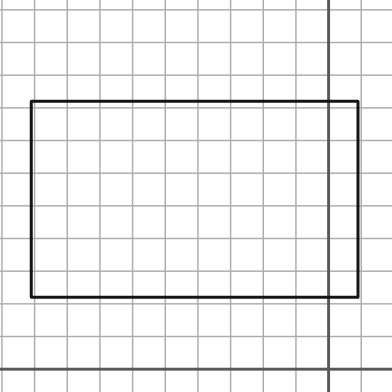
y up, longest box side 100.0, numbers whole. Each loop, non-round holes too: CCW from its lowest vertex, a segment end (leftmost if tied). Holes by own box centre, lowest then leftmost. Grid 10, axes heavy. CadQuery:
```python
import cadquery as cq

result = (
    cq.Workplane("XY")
    .moveTo(-91.0, 22.0)
    .lineTo(9.0, 22.0)
    .lineTo(9.0, 82.0)
    .lineTo(-91.0, 82.0)
    .close()
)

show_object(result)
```